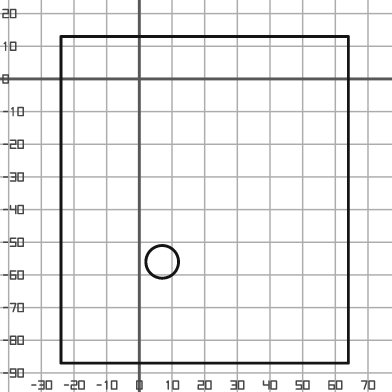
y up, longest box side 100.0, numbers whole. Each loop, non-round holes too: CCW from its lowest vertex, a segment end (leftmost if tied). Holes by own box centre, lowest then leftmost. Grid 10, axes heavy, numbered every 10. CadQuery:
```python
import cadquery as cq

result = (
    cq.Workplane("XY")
    .moveTo(-24.0, -87.0)
    .lineTo(64.0, -87.0)
    .lineTo(64.0, 13.0)
    .lineTo(-24.0, 13.0)
    .close()
    .moveTo(7.0, -56.0)
    .circle(5.0)
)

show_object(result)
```